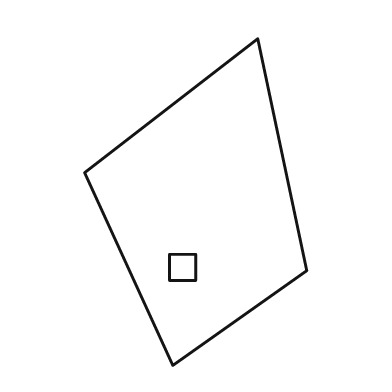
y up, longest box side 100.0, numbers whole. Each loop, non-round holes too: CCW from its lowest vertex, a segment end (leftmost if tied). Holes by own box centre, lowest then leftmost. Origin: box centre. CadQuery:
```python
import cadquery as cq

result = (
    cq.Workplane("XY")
    .moveTo(-7.0, -50.0)
    .lineTo(34.0, -21.0)
    .lineTo(19.0, 50.0)
    .lineTo(-34.0, 9.0)
    .close()
    .moveTo(-8.0, -24.0)
    .lineTo(0.0, -24.0)
    .lineTo(0.0, -16.0)
    .lineTo(-8.0, -16.0)
    .close()
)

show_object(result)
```